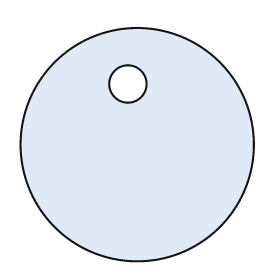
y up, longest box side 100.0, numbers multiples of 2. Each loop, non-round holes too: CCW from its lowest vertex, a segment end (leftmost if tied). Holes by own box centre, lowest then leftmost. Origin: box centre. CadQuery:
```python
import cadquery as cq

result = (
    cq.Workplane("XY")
    .moveTo(0.0, 0.0)
    .circle(50.0)
    .moveTo(-4.0, 26.0)
    .circle(8.0)
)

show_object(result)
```